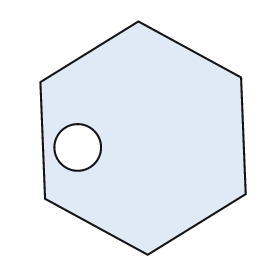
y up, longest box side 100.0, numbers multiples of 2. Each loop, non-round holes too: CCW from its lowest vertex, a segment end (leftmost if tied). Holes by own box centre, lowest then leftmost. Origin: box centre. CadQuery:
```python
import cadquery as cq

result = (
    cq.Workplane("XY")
    .moveTo(2.0, -50.0)
    .lineTo(44.0, -24.0)
    .lineTo(42.0, 26.0)
    .lineTo(-2.0, 50.0)
    .lineTo(-44.0, 24.0)
    .lineTo(-42.0, -26.0)
    .close()
    .moveTo(-28.0, -4.0)
    .circle(10.0)
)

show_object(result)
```